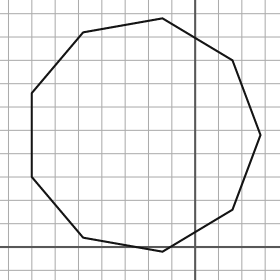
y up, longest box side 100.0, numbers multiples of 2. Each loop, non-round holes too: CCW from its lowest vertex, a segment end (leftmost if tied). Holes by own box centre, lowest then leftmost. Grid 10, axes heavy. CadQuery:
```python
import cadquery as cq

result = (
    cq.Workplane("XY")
    .moveTo(-14.0, -2.0)
    .lineTo(16.0, 16.0)
    .lineTo(28.0, 48.0)
    .lineTo(16.0, 80.0)
    .lineTo(-14.0, 98.0)
    .lineTo(-48.0, 92.0)
    .lineTo(-70.0, 66.0)
    .lineTo(-70.0, 30.0)
    .lineTo(-48.0, 4.0)
    .close()
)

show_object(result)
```